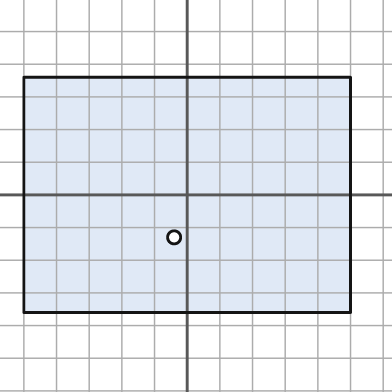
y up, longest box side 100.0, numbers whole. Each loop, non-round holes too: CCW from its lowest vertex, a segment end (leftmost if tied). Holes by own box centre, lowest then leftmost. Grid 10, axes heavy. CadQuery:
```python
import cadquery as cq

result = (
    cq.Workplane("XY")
    .moveTo(-50.0, -36.0)
    .lineTo(50.0, -36.0)
    .lineTo(50.0, 36.0)
    .lineTo(-50.0, 36.0)
    .close()
    .moveTo(-4.0, -13.0)
    .circle(2.0)
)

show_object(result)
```